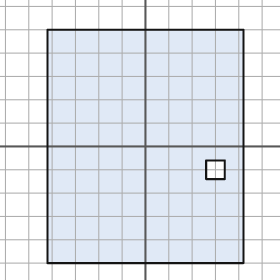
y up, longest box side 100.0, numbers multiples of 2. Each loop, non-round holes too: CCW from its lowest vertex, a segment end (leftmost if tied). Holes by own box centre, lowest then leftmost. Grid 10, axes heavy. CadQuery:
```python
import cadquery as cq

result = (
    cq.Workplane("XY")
    .moveTo(-42.0, -50.0)
    .lineTo(42.0, -50.0)
    .lineTo(42.0, 50.0)
    .lineTo(-42.0, 50.0)
    .close()
    .moveTo(26.0, -14.0)
    .lineTo(34.0, -14.0)
    .lineTo(34.0, -6.0)
    .lineTo(26.0, -6.0)
    .close()
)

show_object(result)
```